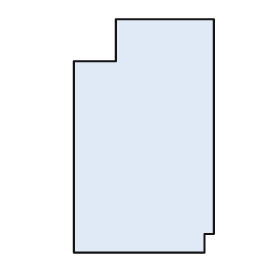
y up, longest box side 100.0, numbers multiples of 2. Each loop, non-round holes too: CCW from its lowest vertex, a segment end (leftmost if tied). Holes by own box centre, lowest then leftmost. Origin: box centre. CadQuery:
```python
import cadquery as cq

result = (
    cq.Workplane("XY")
    .moveTo(-30.0, -50.0)
    .lineTo(26.0, -50.0)
    .lineTo(26.0, -42.0)
    .lineTo(30.0, -42.0)
    .lineTo(30.0, 50.0)
    .lineTo(-12.0, 50.0)
    .lineTo(-12.0, 32.0)
    .lineTo(-30.0, 32.0)
    .close()
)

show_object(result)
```